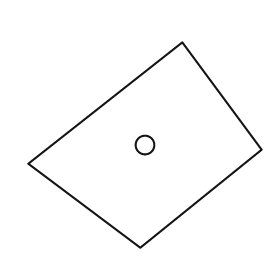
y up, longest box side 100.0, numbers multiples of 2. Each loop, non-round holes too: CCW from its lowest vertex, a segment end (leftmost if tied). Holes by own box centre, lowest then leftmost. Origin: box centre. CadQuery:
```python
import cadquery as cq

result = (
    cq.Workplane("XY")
    .moveTo(-2.0, -44.0)
    .lineTo(50.0, -2.0)
    .lineTo(16.0, 44.0)
    .lineTo(-50.0, -8.0)
    .close()
    .moveTo(0.0, 0.0)
    .circle(4.0)
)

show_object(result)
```